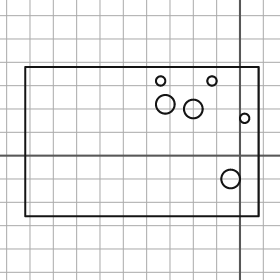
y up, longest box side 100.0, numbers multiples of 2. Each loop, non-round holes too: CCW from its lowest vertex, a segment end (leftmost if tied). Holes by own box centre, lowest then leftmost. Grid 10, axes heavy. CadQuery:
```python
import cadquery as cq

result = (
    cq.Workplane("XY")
    .moveTo(-92.0, -26.0)
    .lineTo(8.0, -26.0)
    .lineTo(8.0, 38.0)
    .lineTo(-92.0, 38.0)
    .close()
    .moveTo(-4.0, -10.0)
    .circle(4.0)
    .moveTo(2.0, 16.0)
    .circle(2.0)
    .moveTo(-20.0, 20.0)
    .circle(4.0)
    .moveTo(-32.0, 22.0)
    .circle(4.0)
    .moveTo(-34.0, 32.0)
    .circle(2.0)
    .moveTo(-12.0, 32.0)
    .circle(2.0)
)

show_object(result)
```